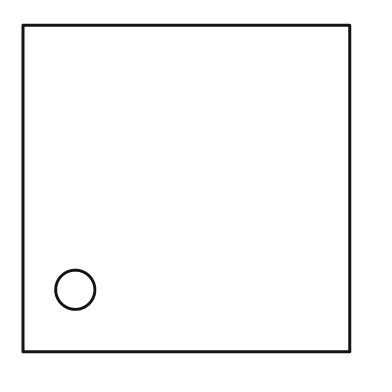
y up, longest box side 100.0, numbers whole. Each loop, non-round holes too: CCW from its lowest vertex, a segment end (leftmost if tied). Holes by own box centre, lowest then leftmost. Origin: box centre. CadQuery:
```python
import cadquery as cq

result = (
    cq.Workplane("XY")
    .moveTo(-50.0, -50.0)
    .lineTo(50.0, -50.0)
    .lineTo(50.0, 50.0)
    .lineTo(-50.0, 50.0)
    .close()
    .moveTo(-34.0, -31.0)
    .circle(6.0)
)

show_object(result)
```